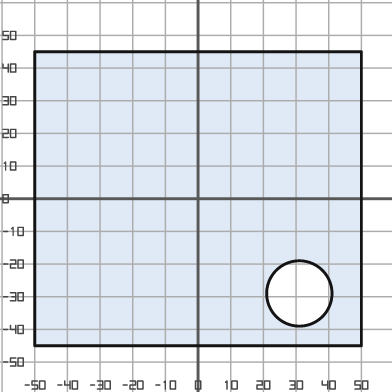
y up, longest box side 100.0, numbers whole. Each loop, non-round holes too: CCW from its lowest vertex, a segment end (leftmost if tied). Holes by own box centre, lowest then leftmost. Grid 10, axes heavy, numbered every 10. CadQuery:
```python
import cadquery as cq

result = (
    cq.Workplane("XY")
    .moveTo(-50.0, -45.0)
    .lineTo(50.0, -45.0)
    .lineTo(50.0, 45.0)
    .lineTo(-50.0, 45.0)
    .close()
    .moveTo(31.0, -29.0)
    .circle(10.0)
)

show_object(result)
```